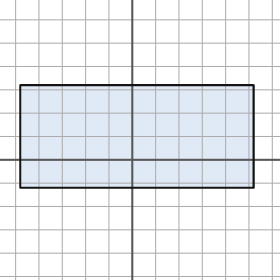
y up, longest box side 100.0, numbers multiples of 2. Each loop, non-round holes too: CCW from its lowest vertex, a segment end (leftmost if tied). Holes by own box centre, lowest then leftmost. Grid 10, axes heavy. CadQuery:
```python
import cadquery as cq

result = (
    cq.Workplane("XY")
    .moveTo(-48.0, -12.0)
    .lineTo(52.0, -12.0)
    .lineTo(52.0, 32.0)
    .lineTo(-48.0, 32.0)
    .close()
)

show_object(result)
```